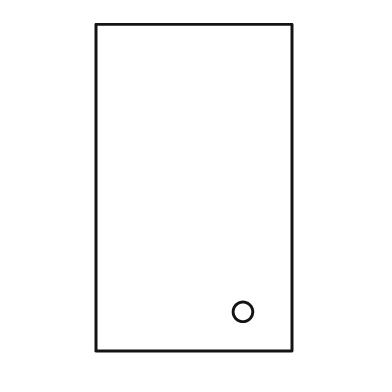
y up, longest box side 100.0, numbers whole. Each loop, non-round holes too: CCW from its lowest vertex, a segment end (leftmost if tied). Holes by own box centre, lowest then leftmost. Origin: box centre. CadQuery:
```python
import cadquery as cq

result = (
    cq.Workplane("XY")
    .moveTo(-30.0, -50.0)
    .lineTo(30.0, -50.0)
    .lineTo(30.0, 50.0)
    .lineTo(-30.0, 50.0)
    .close()
    .moveTo(15.0, -38.0)
    .circle(3.0)
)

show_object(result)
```